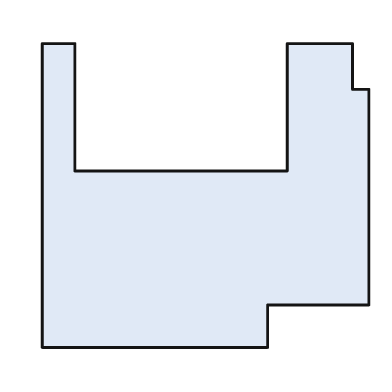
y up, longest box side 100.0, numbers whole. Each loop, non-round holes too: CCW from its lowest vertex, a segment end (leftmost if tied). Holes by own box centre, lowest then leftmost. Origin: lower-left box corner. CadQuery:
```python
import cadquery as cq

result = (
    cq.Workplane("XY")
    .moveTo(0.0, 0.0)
    .lineTo(69.0, 0.0)
    .lineTo(69.0, 13.0)
    .lineTo(100.0, 13.0)
    .lineTo(100.0, 79.0)
    .lineTo(95.0, 79.0)
    .lineTo(95.0, 93.0)
    .lineTo(75.0, 93.0)
    .lineTo(75.0, 54.0)
    .lineTo(10.0, 54.0)
    .lineTo(10.0, 93.0)
    .lineTo(0.0, 93.0)
    .close()
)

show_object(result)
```